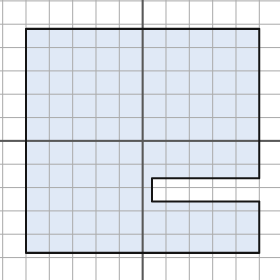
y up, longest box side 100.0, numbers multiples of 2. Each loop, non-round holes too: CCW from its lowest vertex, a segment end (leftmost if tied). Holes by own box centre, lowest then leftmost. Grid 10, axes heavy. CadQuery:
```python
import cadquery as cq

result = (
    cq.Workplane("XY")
    .moveTo(-50.0, -48.0)
    .lineTo(50.0, -48.0)
    .lineTo(50.0, -26.0)
    .lineTo(4.0, -26.0)
    .lineTo(4.0, -16.0)
    .lineTo(50.0, -16.0)
    .lineTo(50.0, 48.0)
    .lineTo(-50.0, 48.0)
    .close()
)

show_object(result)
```